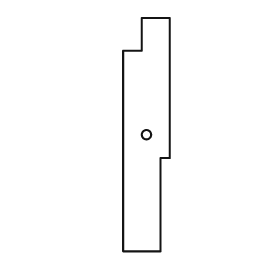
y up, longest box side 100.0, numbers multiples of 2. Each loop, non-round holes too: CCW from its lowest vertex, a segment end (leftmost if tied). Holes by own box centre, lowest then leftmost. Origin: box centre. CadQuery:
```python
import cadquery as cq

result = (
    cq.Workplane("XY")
    .moveTo(-10.0, -50.0)
    .lineTo(6.0, -50.0)
    .lineTo(6.0, -10.0)
    .lineTo(10.0, -10.0)
    .lineTo(10.0, 50.0)
    .lineTo(-2.0, 50.0)
    .lineTo(-2.0, 36.0)
    .lineTo(-10.0, 36.0)
    .close()
    .moveTo(0.0, 0.0)
    .circle(2.0)
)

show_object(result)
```